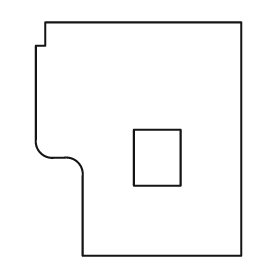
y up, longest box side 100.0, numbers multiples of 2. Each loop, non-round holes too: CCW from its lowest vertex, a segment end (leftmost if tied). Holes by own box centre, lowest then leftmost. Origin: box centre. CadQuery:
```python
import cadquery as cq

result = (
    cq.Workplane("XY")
    .moveTo(-24.0, -50.0)
    .lineTo(44.0, -50.0)
    .lineTo(44.0, 50.0)
    .lineTo(-40.0, 50.0)
    .lineTo(-40.0, 40.0)
    .lineTo(-44.0, 40.0)
    .lineTo(-44.0, 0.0)
    .threePointArc((-42.0, -6.0), (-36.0, -8.0))
    .lineTo(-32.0, -8.0)
    .threePointArc((-26.0, -10.0), (-24.0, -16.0))
    .close()
    .moveTo(-2.0, -20.0)
    .lineTo(18.0, -20.0)
    .lineTo(18.0, 4.0)
    .lineTo(-2.0, 4.0)
    .close()
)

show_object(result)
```